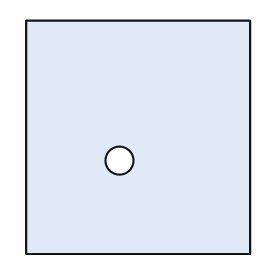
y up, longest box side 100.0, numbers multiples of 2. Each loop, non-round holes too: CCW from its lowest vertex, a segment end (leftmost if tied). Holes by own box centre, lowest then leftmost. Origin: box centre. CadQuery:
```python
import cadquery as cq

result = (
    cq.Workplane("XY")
    .moveTo(-48.0, -50.0)
    .lineTo(48.0, -50.0)
    .lineTo(48.0, 50.0)
    .lineTo(-48.0, 50.0)
    .close()
    .moveTo(-8.0, -10.0)
    .circle(6.0)
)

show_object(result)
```